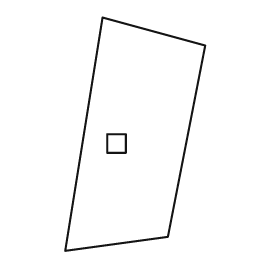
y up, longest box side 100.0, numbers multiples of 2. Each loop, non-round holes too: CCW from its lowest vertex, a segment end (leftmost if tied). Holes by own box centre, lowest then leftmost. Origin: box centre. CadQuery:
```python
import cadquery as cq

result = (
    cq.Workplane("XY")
    .moveTo(-30.0, -50.0)
    .lineTo(14.0, -44.0)
    .lineTo(30.0, 38.0)
    .lineTo(-14.0, 50.0)
    .close()
    .moveTo(-12.0, -8.0)
    .lineTo(-4.0, -8.0)
    .lineTo(-4.0, 0.0)
    .lineTo(-12.0, 0.0)
    .close()
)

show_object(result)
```